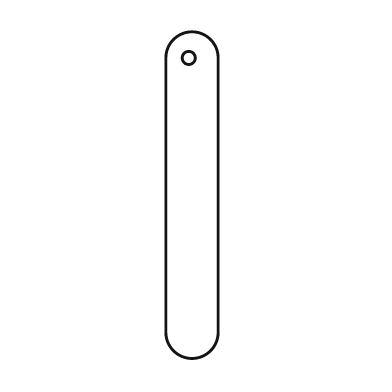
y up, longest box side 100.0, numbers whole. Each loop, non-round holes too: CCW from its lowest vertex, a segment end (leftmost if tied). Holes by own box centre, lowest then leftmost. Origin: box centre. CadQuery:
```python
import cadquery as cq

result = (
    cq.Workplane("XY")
    .moveTo(-8.0, -42.0)
    .threePointArc((0.0, -50.0), (8.0, -42.0))
    .lineTo(8.0, 42.0)
    .threePointArc((0.0, 50.0), (-8.0, 42.0))
    .close()
    .moveTo(-1.0, 42.0)
    .circle(2.0)
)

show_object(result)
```